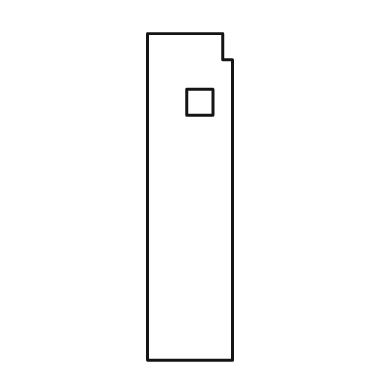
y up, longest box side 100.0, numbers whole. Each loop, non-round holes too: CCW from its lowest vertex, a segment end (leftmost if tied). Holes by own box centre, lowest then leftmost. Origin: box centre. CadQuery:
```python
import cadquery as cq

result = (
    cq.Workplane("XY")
    .moveTo(-13.0, -50.0)
    .lineTo(13.0, -50.0)
    .lineTo(13.0, 42.0)
    .lineTo(10.0, 42.0)
    .lineTo(10.0, 50.0)
    .lineTo(-13.0, 50.0)
    .close()
    .moveTo(-1.0, 25.0)
    .lineTo(7.0, 25.0)
    .lineTo(7.0, 33.0)
    .lineTo(-1.0, 33.0)
    .close()
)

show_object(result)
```